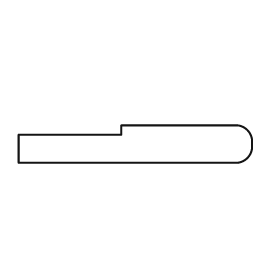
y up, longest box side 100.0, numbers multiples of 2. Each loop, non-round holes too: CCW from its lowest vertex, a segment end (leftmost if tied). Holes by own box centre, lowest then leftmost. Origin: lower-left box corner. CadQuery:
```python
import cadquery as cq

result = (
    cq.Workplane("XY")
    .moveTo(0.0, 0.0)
    .lineTo(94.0, 0.0)
    .threePointArc((98.0, 2.0), (100.0, 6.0))
    .lineTo(100.0, 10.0)
    .threePointArc((98.0, 14.0), (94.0, 16.0))
    .lineTo(44.0, 16.0)
    .lineTo(44.0, 12.0)
    .lineTo(0.0, 12.0)
    .close()
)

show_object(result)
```